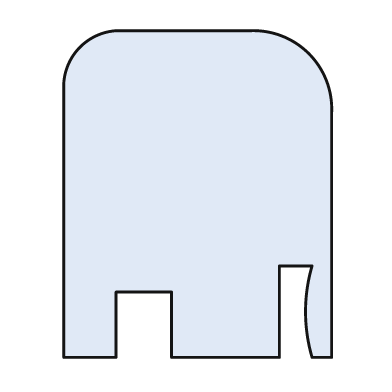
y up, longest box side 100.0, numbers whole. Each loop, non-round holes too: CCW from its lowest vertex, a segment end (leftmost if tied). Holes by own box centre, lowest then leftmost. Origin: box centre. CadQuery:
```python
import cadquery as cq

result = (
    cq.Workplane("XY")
    .moveTo(-41.0, -50.0)
    .lineTo(-25.0, -50.0)
    .lineTo(-25.0, -30.0)
    .lineTo(-8.0, -30.0)
    .lineTo(-8.0, -50.0)
    .lineTo(25.0, -50.0)
    .lineTo(25.0, -22.0)
    .lineTo(35.0, -22.0)
    .threePointArc((33.0, -36.0), (35.0, -50.0))
    .lineTo(41.0, -50.0)
    .lineTo(41.0, 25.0)
    .threePointArc((34.0, 43.0), (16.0, 50.0))
    .lineTo(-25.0, 50.0)
    .threePointArc((-36.0, 45.0), (-41.0, 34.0))
    .close()
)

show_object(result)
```